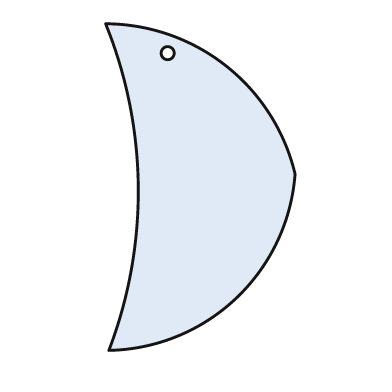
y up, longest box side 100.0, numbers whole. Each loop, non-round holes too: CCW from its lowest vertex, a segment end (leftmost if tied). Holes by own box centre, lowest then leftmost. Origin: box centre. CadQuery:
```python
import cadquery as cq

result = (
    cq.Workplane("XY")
    .moveTo(-28.0, -50.0)
    .threePointArc((11.0, -34.0), (29.0, 4.0))
    .threePointArc((8.0, 37.0), (-29.0, 50.0))
    .threePointArc((-19.0, 0.0), (-28.0, -50.0))
    .close()
    .moveTo(-10.0, 41.0)
    .circle(2.0)
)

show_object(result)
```